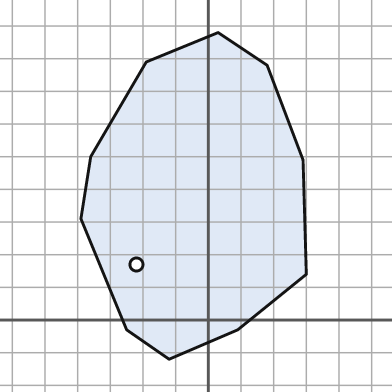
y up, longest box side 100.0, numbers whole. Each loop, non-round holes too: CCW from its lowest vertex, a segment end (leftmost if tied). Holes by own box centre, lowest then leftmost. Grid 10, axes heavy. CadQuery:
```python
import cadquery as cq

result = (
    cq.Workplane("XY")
    .moveTo(-12.0, -12.0)
    .lineTo(9.0, -3.0)
    .lineTo(30.0, 14.0)
    .lineTo(29.0, 49.0)
    .lineTo(18.0, 78.0)
    .lineTo(3.0, 88.0)
    .lineTo(-19.0, 79.0)
    .lineTo(-36.0, 50.0)
    .lineTo(-39.0, 31.0)
    .lineTo(-25.0, -3.0)
    .close()
    .moveTo(-22.0, 17.0)
    .circle(2.0)
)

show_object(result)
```